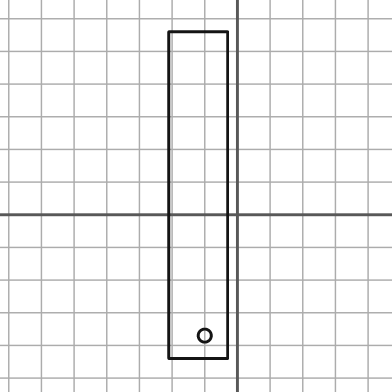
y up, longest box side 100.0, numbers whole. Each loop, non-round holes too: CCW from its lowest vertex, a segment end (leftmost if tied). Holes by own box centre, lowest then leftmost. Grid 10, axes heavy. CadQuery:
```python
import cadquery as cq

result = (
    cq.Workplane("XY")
    .moveTo(-21.0, -44.0)
    .lineTo(-3.0, -44.0)
    .lineTo(-3.0, 56.0)
    .lineTo(-21.0, 56.0)
    .close()
    .moveTo(-10.0, -37.0)
    .circle(2.0)
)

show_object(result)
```